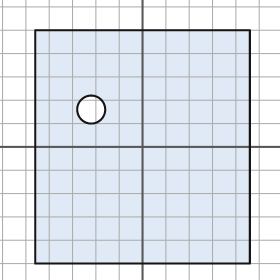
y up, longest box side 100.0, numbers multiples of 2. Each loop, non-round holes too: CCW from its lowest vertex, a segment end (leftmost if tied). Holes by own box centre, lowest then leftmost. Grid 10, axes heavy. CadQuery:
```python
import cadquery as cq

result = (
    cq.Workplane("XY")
    .moveTo(-46.0, -50.0)
    .lineTo(46.0, -50.0)
    .lineTo(46.0, 50.0)
    .lineTo(-46.0, 50.0)
    .close()
    .moveTo(-22.0, 16.0)
    .circle(6.0)
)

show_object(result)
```